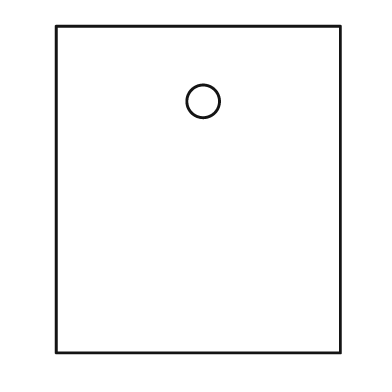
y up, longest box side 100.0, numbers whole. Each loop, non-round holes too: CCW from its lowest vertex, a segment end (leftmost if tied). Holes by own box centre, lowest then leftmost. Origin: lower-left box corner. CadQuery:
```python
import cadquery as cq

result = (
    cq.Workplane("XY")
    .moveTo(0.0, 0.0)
    .lineTo(87.0, 0.0)
    .lineTo(87.0, 100.0)
    .lineTo(0.0, 100.0)
    .close()
    .moveTo(45.0, 77.0)
    .circle(5.0)
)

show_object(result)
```